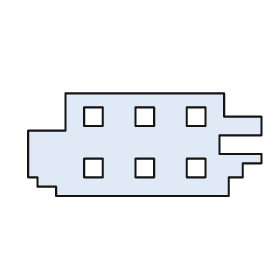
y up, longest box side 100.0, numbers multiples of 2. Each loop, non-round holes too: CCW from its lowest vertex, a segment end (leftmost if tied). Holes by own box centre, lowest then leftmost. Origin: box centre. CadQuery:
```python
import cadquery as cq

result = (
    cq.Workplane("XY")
    .moveTo(-38.0, -22.0)
    .lineTo(36.0, -22.0)
    .lineTo(36.0, -14.0)
    .lineTo(42.0, -14.0)
    .lineTo(42.0, -8.0)
    .lineTo(50.0, -8.0)
    .lineTo(50.0, -4.0)
    .lineTo(32.0, -4.0)
    .lineTo(32.0, 4.0)
    .lineTo(50.0, 4.0)
    .lineTo(50.0, 12.0)
    .lineTo(34.0, 12.0)
    .lineTo(34.0, 22.0)
    .lineTo(-34.0, 22.0)
    .lineTo(-34.0, 6.0)
    .lineTo(-50.0, 6.0)
    .lineTo(-50.0, -14.0)
    .lineTo(-46.0, -14.0)
    .lineTo(-46.0, -18.0)
    .lineTo(-38.0, -18.0)
    .close()
    .moveTo(-26.0, -14.0)
    .lineTo(-18.0, -14.0)
    .lineTo(-18.0, -6.0)
    .lineTo(-26.0, -6.0)
    .close()
    .moveTo(-4.0, -14.0)
    .lineTo(4.0, -14.0)
    .lineTo(4.0, -6.0)
    .lineTo(-4.0, -6.0)
    .close()
    .moveTo(18.0, -14.0)
    .lineTo(26.0, -14.0)
    .lineTo(26.0, -6.0)
    .lineTo(18.0, -6.0)
    .close()
    .moveTo(-26.0, 8.0)
    .lineTo(-18.0, 8.0)
    .lineTo(-18.0, 16.0)
    .lineTo(-26.0, 16.0)
    .close()
    .moveTo(-4.0, 8.0)
    .lineTo(4.0, 8.0)
    .lineTo(4.0, 16.0)
    .lineTo(-4.0, 16.0)
    .close()
    .moveTo(18.0, 8.0)
    .lineTo(26.0, 8.0)
    .lineTo(26.0, 16.0)
    .lineTo(18.0, 16.0)
    .close()
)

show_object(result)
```